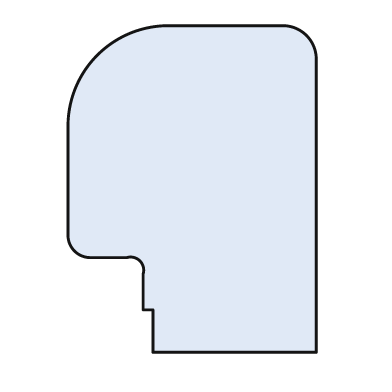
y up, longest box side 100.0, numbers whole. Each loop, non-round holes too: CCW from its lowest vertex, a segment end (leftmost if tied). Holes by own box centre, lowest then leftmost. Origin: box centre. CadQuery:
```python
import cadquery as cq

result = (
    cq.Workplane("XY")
    .moveTo(-12.0, -50.0)
    .lineTo(38.0, -50.0)
    .lineTo(38.0, 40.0)
    .threePointArc((35.0, 47.0), (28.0, 50.0))
    .lineTo(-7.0, 50.0)
    .threePointArc((-29.0, 41.0), (-38.0, 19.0))
    .lineTo(-38.0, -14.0)
    .threePointArc((-36.0, -19.0), (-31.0, -21.0))
    .lineTo(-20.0, -21.0)
    .threePointArc((-16.0, -22.0), (-15.0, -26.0))
    .lineTo(-15.0, -37.0)
    .lineTo(-12.0, -37.0)
    .close()
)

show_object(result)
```